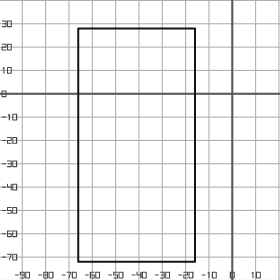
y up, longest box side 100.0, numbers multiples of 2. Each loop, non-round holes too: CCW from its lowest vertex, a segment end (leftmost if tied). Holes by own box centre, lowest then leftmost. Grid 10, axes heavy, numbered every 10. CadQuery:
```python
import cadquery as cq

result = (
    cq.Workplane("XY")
    .moveTo(-66.0, -72.0)
    .lineTo(-16.0, -72.0)
    .lineTo(-16.0, 28.0)
    .lineTo(-66.0, 28.0)
    .close()
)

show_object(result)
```